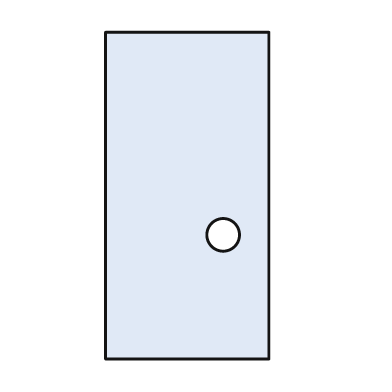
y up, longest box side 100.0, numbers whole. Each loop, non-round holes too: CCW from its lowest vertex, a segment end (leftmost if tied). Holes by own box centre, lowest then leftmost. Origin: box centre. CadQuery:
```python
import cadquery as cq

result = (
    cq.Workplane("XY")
    .moveTo(-25.0, -50.0)
    .lineTo(25.0, -50.0)
    .lineTo(25.0, 50.0)
    .lineTo(-25.0, 50.0)
    .close()
    .moveTo(11.0, -12.0)
    .circle(5.0)
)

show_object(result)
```